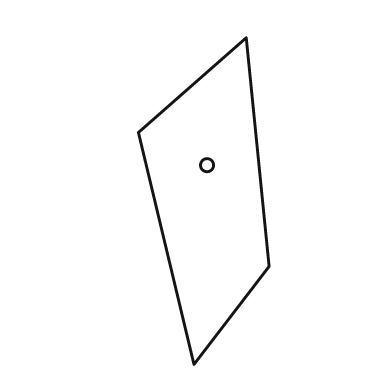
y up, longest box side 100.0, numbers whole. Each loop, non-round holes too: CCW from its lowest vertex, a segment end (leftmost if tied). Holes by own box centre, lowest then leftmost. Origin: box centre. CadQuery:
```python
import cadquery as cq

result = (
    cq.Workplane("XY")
    .moveTo(-3.0, -50.0)
    .lineTo(20.0, -20.0)
    .lineTo(13.0, 50.0)
    .lineTo(-20.0, 21.0)
    .close()
    .moveTo(1.0, 11.0)
    .circle(2.0)
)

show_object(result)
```